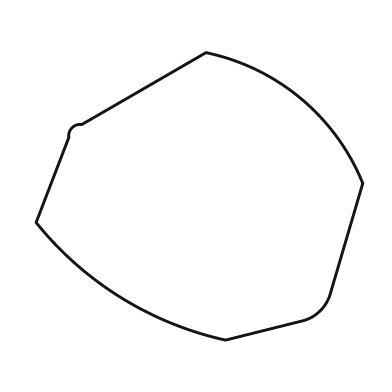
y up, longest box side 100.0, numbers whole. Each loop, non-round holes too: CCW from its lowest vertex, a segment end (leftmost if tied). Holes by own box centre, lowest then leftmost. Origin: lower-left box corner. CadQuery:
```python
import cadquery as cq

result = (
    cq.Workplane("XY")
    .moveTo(58.0, 0.0)
    .lineTo(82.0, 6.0)
    .threePointArc((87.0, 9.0), (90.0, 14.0))
    .lineTo(100.0, 48.0)
    .threePointArc((81.0, 74.0), (52.0, 88.0))
    .lineTo(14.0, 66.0)
    .threePointArc((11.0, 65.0), (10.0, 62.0))
    .lineTo(0.0, 36.0)
    .threePointArc((26.0, 13.0), (58.0, 0.0))
    .close()
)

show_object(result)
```